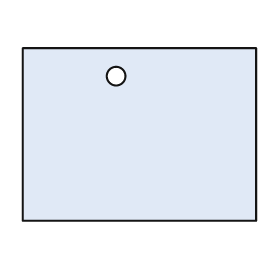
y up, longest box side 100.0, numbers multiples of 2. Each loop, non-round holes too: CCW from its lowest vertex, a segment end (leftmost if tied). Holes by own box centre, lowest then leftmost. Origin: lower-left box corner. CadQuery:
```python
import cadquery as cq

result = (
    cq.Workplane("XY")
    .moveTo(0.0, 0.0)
    .lineTo(100.0, 0.0)
    .lineTo(100.0, 74.0)
    .lineTo(0.0, 74.0)
    .close()
    .moveTo(40.0, 62.0)
    .circle(4.0)
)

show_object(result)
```